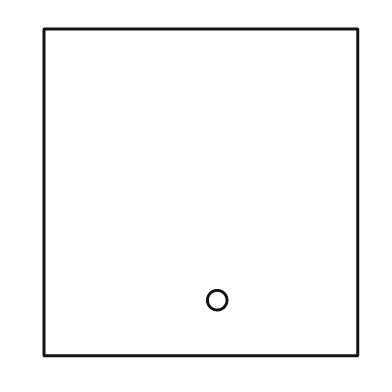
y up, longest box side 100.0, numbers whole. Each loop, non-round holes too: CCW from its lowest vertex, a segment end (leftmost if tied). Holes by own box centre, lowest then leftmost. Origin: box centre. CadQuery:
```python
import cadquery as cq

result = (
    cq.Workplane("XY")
    .moveTo(-48.0, -50.0)
    .lineTo(48.0, -50.0)
    .lineTo(48.0, 50.0)
    .lineTo(-48.0, 50.0)
    .close()
    .moveTo(5.0, -33.0)
    .circle(3.0)
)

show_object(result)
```